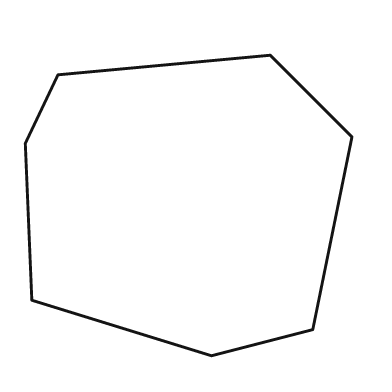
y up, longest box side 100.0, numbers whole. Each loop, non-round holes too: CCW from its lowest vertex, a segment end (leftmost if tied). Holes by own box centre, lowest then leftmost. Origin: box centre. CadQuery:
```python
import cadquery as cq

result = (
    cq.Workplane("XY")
    .moveTo(7.0, -46.0)
    .lineTo(38.0, -38.0)
    .lineTo(50.0, 21.0)
    .lineTo(25.0, 46.0)
    .lineTo(-40.0, 40.0)
    .lineTo(-50.0, 19.0)
    .lineTo(-48.0, -29.0)
    .close()
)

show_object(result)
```